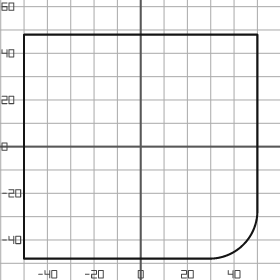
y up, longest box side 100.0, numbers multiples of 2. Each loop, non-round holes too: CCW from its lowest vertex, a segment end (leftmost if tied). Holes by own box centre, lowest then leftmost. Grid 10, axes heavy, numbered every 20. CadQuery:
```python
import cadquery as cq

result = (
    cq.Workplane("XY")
    .moveTo(-50.0, -48.0)
    .lineTo(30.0, -48.0)
    .threePointArc((44.0, -42.0), (50.0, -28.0))
    .lineTo(50.0, 48.0)
    .lineTo(-50.0, 48.0)
    .close()
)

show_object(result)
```